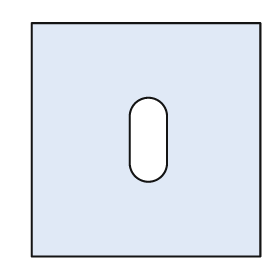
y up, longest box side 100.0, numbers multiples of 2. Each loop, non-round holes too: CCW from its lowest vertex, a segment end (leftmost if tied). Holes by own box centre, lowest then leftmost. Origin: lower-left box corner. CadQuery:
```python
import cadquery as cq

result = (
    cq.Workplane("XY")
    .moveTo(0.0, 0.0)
    .lineTo(98.0, 0.0)
    .lineTo(98.0, 100.0)
    .lineTo(0.0, 100.0)
    .close()
    .moveTo(42.0, 40.0)
    .threePointArc((50.0, 32.0), (58.0, 40.0))
    .lineTo(58.0, 60.0)
    .threePointArc((50.0, 68.0), (42.0, 60.0))
    .close()
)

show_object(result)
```